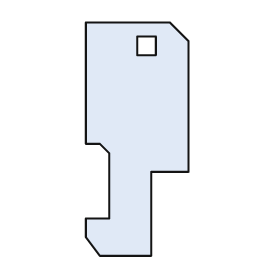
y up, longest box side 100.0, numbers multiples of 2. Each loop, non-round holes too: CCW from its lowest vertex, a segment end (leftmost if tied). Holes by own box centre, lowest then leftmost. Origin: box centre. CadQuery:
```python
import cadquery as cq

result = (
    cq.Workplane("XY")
    .moveTo(-16.0, -50.0)
    .lineTo(6.0, -50.0)
    .lineTo(6.0, -14.0)
    .lineTo(22.0, -14.0)
    .lineTo(22.0, 42.0)
    .lineTo(14.0, 50.0)
    .lineTo(-22.0, 50.0)
    .lineTo(-22.0, -2.0)
    .lineTo(-16.0, -2.0)
    .lineTo(-12.0, -6.0)
    .lineTo(-12.0, -34.0)
    .lineTo(-22.0, -34.0)
    .lineTo(-22.0, -42.0)
    .close()
    .moveTo(0.0, 36.0)
    .lineTo(8.0, 36.0)
    .lineTo(8.0, 44.0)
    .lineTo(0.0, 44.0)
    .close()
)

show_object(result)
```